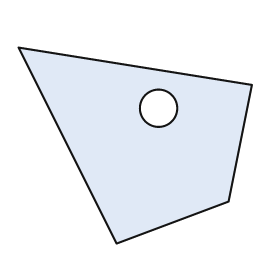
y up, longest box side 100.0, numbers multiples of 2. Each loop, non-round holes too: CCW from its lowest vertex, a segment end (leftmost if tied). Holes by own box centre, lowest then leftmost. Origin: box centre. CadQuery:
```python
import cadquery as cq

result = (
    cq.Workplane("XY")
    .moveTo(-8.0, -42.0)
    .lineTo(40.0, -24.0)
    .lineTo(50.0, 26.0)
    .lineTo(-50.0, 42.0)
    .close()
    .moveTo(10.0, 16.0)
    .circle(8.0)
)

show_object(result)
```